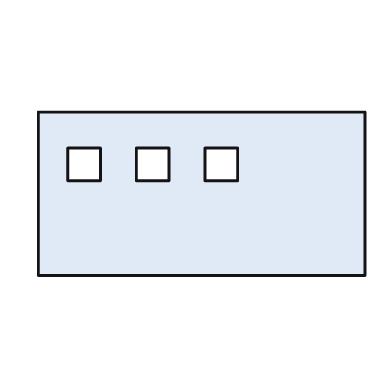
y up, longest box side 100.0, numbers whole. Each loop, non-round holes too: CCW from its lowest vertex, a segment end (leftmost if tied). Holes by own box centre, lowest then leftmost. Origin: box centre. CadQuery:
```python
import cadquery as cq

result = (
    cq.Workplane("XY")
    .moveTo(-50.0, -25.0)
    .lineTo(50.0, -25.0)
    .lineTo(50.0, 25.0)
    .lineTo(-50.0, 25.0)
    .close()
    .moveTo(-41.0, 4.0)
    .lineTo(-31.0, 4.0)
    .lineTo(-31.0, 14.0)
    .lineTo(-41.0, 14.0)
    .close()
    .moveTo(-20.0, 4.0)
    .lineTo(-10.0, 4.0)
    .lineTo(-10.0, 14.0)
    .lineTo(-20.0, 14.0)
    .close()
    .moveTo(1.0, 4.0)
    .lineTo(11.0, 4.0)
    .lineTo(11.0, 14.0)
    .lineTo(1.0, 14.0)
    .close()
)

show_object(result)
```